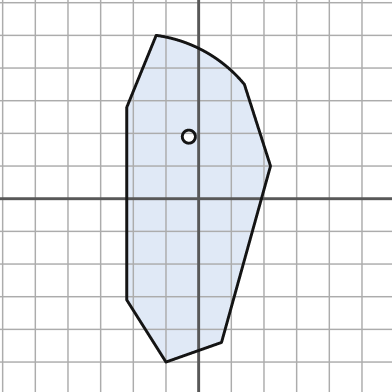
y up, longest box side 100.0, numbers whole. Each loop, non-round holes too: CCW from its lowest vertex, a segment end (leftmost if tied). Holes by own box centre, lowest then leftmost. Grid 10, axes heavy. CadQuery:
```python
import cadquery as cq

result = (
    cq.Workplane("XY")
    .moveTo(-10.0, -50.0)
    .lineTo(7.0, -44.0)
    .lineTo(22.0, 10.0)
    .lineTo(14.0, 35.0)
    .threePointArc((2.0, 45.0), (-13.0, 50.0))
    .lineTo(-22.0, 28.0)
    .lineTo(-22.0, -31.0)
    .close()
    .moveTo(-3.0, 19.0)
    .circle(2.0)
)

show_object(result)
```